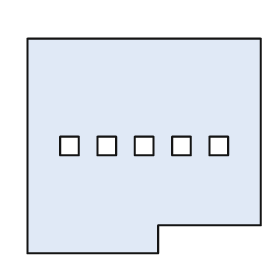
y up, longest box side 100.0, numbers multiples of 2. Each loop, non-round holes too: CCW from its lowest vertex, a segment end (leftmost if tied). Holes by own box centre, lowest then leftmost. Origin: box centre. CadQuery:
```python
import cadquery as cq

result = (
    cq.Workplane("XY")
    .moveTo(-50.0, -46.0)
    .lineTo(6.0, -46.0)
    .lineTo(6.0, -34.0)
    .lineTo(50.0, -34.0)
    .lineTo(50.0, 46.0)
    .lineTo(-50.0, 46.0)
    .close()
    .moveTo(-36.0, -4.0)
    .lineTo(-28.0, -4.0)
    .lineTo(-28.0, 4.0)
    .lineTo(-36.0, 4.0)
    .close()
    .moveTo(-20.0, -4.0)
    .lineTo(-12.0, -4.0)
    .lineTo(-12.0, 4.0)
    .lineTo(-20.0, 4.0)
    .close()
    .moveTo(-4.0, -4.0)
    .lineTo(4.0, -4.0)
    .lineTo(4.0, 4.0)
    .lineTo(-4.0, 4.0)
    .close()
    .moveTo(12.0, -4.0)
    .lineTo(20.0, -4.0)
    .lineTo(20.0, 4.0)
    .lineTo(12.0, 4.0)
    .close()
    .moveTo(28.0, -4.0)
    .lineTo(36.0, -4.0)
    .lineTo(36.0, 4.0)
    .lineTo(28.0, 4.0)
    .close()
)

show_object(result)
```